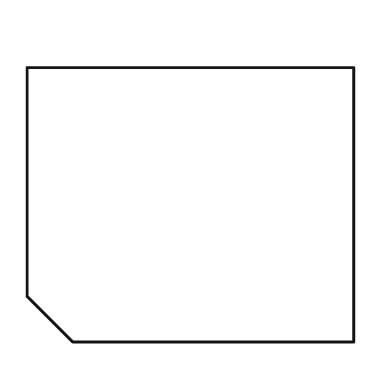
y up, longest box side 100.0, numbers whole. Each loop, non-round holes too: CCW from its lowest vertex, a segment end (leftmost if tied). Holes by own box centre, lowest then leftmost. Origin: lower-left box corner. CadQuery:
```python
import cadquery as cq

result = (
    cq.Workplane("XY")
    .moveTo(14.0, 0.0)
    .lineTo(100.0, 0.0)
    .lineTo(100.0, 84.0)
    .lineTo(0.0, 84.0)
    .lineTo(0.0, 14.0)
    .close()
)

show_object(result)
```